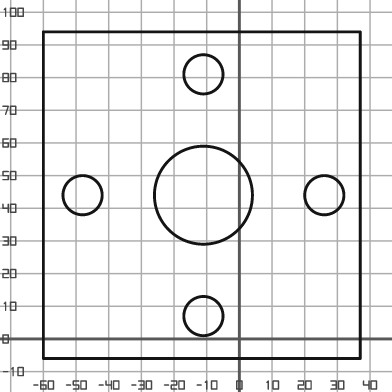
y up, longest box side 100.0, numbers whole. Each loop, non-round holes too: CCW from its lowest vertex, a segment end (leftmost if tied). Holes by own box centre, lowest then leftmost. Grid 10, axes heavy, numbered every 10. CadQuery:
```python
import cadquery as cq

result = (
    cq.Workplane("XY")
    .moveTo(-60.0, -6.0)
    .lineTo(37.0, -6.0)
    .lineTo(37.0, 94.0)
    .lineTo(-60.0, 94.0)
    .close()
    .moveTo(-11.0, 7.0)
    .circle(6.0)
    .moveTo(-48.0, 44.0)
    .circle(6.0)
    .moveTo(-11.0, 44.0)
    .circle(15.0)
    .moveTo(26.0, 44.0)
    .circle(6.0)
    .moveTo(-11.0, 81.0)
    .circle(6.0)
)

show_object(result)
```